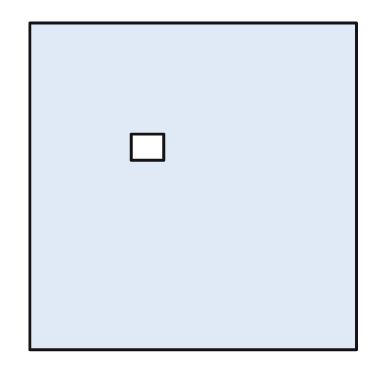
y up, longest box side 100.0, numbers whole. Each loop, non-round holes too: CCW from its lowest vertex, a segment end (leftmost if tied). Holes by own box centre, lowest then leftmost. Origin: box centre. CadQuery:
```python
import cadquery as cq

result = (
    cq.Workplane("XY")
    .moveTo(-50.0, -50.0)
    .lineTo(50.0, -50.0)
    .lineTo(50.0, 50.0)
    .lineTo(-50.0, 50.0)
    .close()
    .moveTo(-19.0, 8.0)
    .lineTo(-9.0, 8.0)
    .lineTo(-9.0, 16.0)
    .lineTo(-19.0, 16.0)
    .close()
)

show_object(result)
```